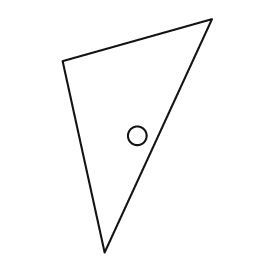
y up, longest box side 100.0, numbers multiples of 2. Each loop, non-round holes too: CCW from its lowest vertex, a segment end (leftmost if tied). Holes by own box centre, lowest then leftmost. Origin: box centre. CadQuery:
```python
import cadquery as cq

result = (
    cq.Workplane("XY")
    .moveTo(-14.0, -50.0)
    .lineTo(32.0, 50.0)
    .lineTo(-32.0, 32.0)
    .close()
    .moveTo(0.0, 0.0)
    .circle(4.0)
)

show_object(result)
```